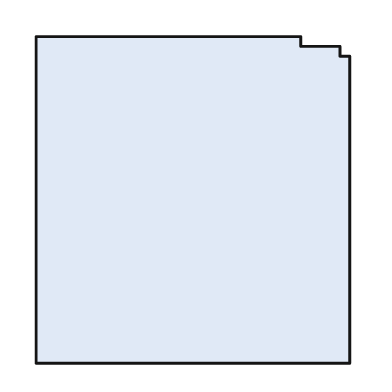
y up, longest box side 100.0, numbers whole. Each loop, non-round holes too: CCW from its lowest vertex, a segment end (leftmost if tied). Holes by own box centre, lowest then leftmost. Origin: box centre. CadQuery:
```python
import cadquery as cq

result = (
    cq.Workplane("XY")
    .moveTo(-48.0, -50.0)
    .lineTo(48.0, -50.0)
    .lineTo(48.0, 44.0)
    .lineTo(45.0, 44.0)
    .lineTo(45.0, 47.0)
    .lineTo(33.0, 47.0)
    .lineTo(33.0, 50.0)
    .lineTo(-48.0, 50.0)
    .close()
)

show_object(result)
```